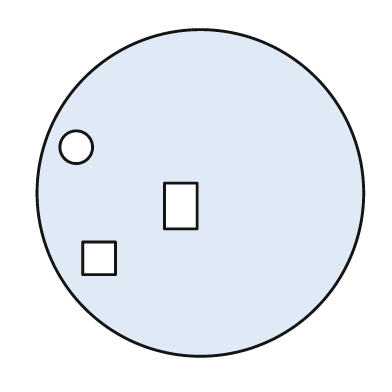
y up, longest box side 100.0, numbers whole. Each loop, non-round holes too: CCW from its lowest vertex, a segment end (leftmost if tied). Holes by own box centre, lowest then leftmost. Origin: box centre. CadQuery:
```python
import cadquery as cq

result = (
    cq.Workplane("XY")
    .moveTo(0.0, 0.0)
    .circle(50.0)
    .moveTo(-36.0, -25.0)
    .lineTo(-26.0, -25.0)
    .lineTo(-26.0, -15.0)
    .lineTo(-36.0, -15.0)
    .close()
    .moveTo(-11.0, -11.0)
    .lineTo(-1.0, -11.0)
    .lineTo(-1.0, 3.0)
    .lineTo(-11.0, 3.0)
    .close()
    .moveTo(-38.0, 14.0)
    .circle(5.0)
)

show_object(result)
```